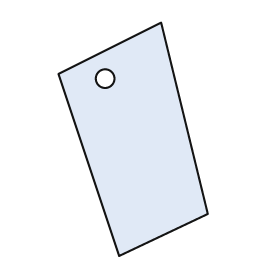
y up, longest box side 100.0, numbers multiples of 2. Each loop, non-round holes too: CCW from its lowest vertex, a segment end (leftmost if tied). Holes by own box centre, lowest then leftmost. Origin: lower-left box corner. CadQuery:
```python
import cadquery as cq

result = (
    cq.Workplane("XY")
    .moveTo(26.0, 0.0)
    .lineTo(64.0, 18.0)
    .lineTo(44.0, 100.0)
    .lineTo(0.0, 78.0)
    .close()
    .moveTo(20.0, 76.0)
    .circle(4.0)
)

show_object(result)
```